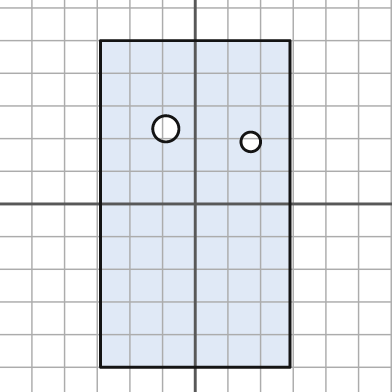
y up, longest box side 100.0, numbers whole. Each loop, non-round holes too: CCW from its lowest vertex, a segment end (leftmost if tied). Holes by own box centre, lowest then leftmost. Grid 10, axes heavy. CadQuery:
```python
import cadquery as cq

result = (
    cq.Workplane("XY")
    .moveTo(-29.0, -50.0)
    .lineTo(29.0, -50.0)
    .lineTo(29.0, 50.0)
    .lineTo(-29.0, 50.0)
    .close()
    .moveTo(17.0, 19.0)
    .circle(3.0)
    .moveTo(-9.0, 23.0)
    .circle(4.0)
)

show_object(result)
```